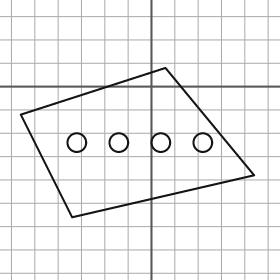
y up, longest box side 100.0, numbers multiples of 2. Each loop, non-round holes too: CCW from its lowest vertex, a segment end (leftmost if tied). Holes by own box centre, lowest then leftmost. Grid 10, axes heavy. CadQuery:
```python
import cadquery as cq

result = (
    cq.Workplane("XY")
    .moveTo(-34.0, -56.0)
    .lineTo(44.0, -38.0)
    .lineTo(6.0, 8.0)
    .lineTo(-56.0, -12.0)
    .close()
    .moveTo(-32.0, -24.0)
    .circle(4.0)
    .moveTo(-14.0, -24.0)
    .circle(4.0)
    .moveTo(4.0, -24.0)
    .circle(4.0)
    .moveTo(22.0, -24.0)
    .circle(4.0)
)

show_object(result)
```